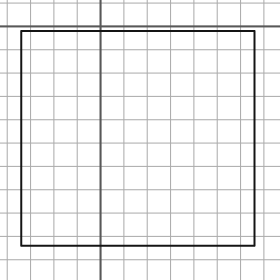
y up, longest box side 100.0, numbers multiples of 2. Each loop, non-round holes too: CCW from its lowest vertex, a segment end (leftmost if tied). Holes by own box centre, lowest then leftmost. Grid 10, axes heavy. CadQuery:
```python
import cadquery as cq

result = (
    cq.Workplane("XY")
    .moveTo(-34.0, -94.0)
    .lineTo(66.0, -94.0)
    .lineTo(66.0, -2.0)
    .lineTo(-34.0, -2.0)
    .close()
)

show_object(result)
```